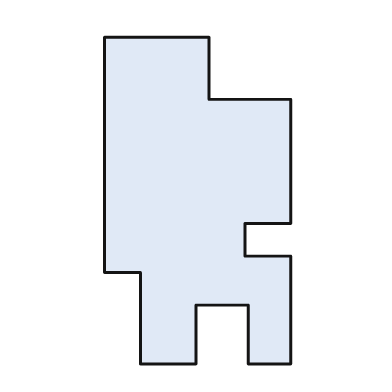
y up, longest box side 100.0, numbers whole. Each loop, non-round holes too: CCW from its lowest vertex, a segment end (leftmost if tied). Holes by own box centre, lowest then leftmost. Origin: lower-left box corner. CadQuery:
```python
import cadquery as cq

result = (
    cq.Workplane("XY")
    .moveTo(11.0, 0.0)
    .lineTo(28.0, 0.0)
    .lineTo(28.0, 18.0)
    .lineTo(44.0, 18.0)
    .lineTo(44.0, 0.0)
    .lineTo(57.0, 0.0)
    .lineTo(57.0, 33.0)
    .lineTo(43.0, 33.0)
    .lineTo(43.0, 43.0)
    .lineTo(57.0, 43.0)
    .lineTo(57.0, 81.0)
    .lineTo(32.0, 81.0)
    .lineTo(32.0, 100.0)
    .lineTo(0.0, 100.0)
    .lineTo(0.0, 28.0)
    .lineTo(11.0, 28.0)
    .close()
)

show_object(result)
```